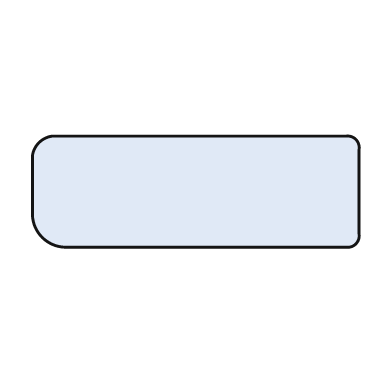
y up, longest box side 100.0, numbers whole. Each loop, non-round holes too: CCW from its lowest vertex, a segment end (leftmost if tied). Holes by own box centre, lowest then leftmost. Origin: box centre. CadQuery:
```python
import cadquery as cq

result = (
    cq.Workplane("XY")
    .moveTo(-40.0, -17.0)
    .lineTo(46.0, -17.0)
    .threePointArc((49.0, -16.0), (50.0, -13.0))
    .lineTo(50.0, 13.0)
    .threePointArc((49.0, 16.0), (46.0, 17.0))
    .lineTo(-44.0, 17.0)
    .threePointArc((-48.0, 15.0), (-50.0, 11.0))
    .lineTo(-50.0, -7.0)
    .threePointArc((-47.0, -14.0), (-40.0, -17.0))
    .close()
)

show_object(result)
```